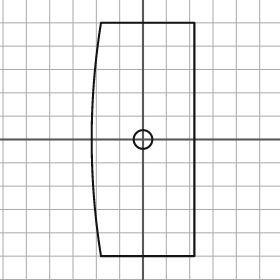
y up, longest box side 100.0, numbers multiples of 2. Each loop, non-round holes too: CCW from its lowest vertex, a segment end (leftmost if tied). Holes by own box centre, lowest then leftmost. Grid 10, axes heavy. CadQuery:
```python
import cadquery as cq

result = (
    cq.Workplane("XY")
    .moveTo(-18.0, -50.0)
    .lineTo(22.0, -50.0)
    .lineTo(22.0, 50.0)
    .lineTo(-18.0, 50.0)
    .threePointArc((-22.0, 0.0), (-18.0, -50.0))
    .close()
    .moveTo(0.0, 0.0)
    .circle(4.0)
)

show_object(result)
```